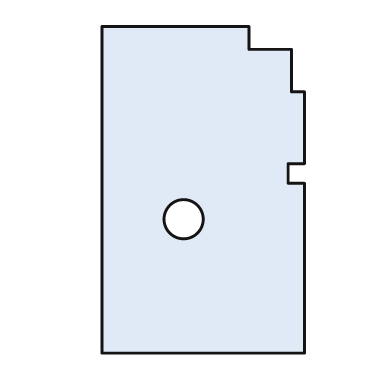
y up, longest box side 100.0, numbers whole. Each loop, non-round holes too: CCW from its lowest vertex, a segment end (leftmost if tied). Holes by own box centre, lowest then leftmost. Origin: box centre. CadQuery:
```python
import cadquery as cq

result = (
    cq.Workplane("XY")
    .moveTo(-31.0, -50.0)
    .lineTo(31.0, -50.0)
    .lineTo(31.0, 2.0)
    .lineTo(26.0, 2.0)
    .lineTo(26.0, 8.0)
    .lineTo(31.0, 8.0)
    .lineTo(31.0, 30.0)
    .lineTo(27.0, 30.0)
    .lineTo(27.0, 43.0)
    .lineTo(14.0, 43.0)
    .lineTo(14.0, 50.0)
    .lineTo(-31.0, 50.0)
    .close()
    .moveTo(-6.0, -9.0)
    .circle(6.0)
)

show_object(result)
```